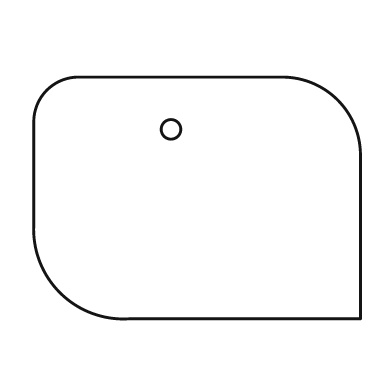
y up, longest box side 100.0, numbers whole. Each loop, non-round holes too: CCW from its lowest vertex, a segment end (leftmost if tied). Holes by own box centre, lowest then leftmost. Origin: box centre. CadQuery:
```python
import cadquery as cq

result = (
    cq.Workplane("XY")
    .moveTo(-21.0, -37.0)
    .lineTo(50.0, -37.0)
    .lineTo(50.0, 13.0)
    .threePointArc((43.0, 30.0), (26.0, 37.0))
    .lineTo(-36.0, 37.0)
    .threePointArc((-46.0, 33.0), (-50.0, 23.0))
    .lineTo(-50.0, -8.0)
    .threePointArc((-42.0, -29.0), (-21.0, -37.0))
    .close()
    .moveTo(-8.0, 21.0)
    .circle(3.0)
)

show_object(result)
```